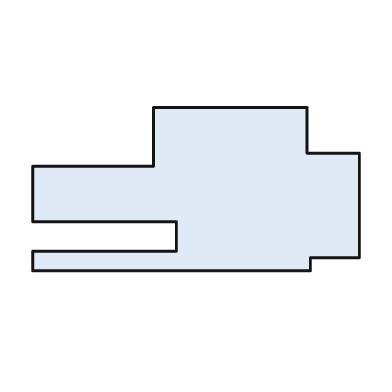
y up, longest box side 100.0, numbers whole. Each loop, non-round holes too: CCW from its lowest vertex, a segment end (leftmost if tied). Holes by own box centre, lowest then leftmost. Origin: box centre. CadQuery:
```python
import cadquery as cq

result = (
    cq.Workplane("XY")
    .moveTo(-50.0, -25.0)
    .lineTo(35.0, -25.0)
    .lineTo(35.0, -21.0)
    .lineTo(50.0, -21.0)
    .lineTo(50.0, 11.0)
    .lineTo(34.0, 11.0)
    .lineTo(34.0, 25.0)
    .lineTo(-13.0, 25.0)
    .lineTo(-13.0, 7.0)
    .lineTo(-50.0, 7.0)
    .lineTo(-50.0, -10.0)
    .lineTo(-6.0, -10.0)
    .lineTo(-6.0, -19.0)
    .lineTo(-50.0, -19.0)
    .close()
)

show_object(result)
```